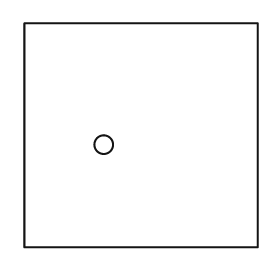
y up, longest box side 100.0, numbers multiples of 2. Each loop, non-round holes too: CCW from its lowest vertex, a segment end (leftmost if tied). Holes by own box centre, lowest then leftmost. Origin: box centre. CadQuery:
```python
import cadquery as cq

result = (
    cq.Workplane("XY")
    .moveTo(-50.0, -48.0)
    .lineTo(50.0, -48.0)
    .lineTo(50.0, 48.0)
    .lineTo(-50.0, 48.0)
    .close()
    .moveTo(-16.0, -4.0)
    .circle(4.0)
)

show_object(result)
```